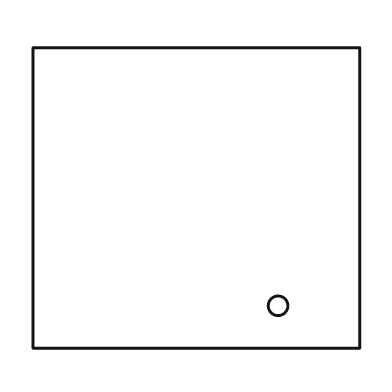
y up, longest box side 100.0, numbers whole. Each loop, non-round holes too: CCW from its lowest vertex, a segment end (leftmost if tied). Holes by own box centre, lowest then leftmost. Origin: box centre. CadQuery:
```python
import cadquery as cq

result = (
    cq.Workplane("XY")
    .moveTo(-50.0, -46.0)
    .lineTo(50.0, -46.0)
    .lineTo(50.0, 46.0)
    .lineTo(-50.0, 46.0)
    .close()
    .moveTo(25.0, -33.0)
    .circle(3.0)
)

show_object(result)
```